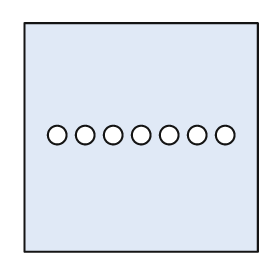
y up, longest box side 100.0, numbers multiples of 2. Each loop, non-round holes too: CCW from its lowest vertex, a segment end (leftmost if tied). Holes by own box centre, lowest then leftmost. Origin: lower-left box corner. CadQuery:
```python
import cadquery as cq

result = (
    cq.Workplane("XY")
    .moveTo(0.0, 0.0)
    .lineTo(100.0, 0.0)
    .lineTo(100.0, 98.0)
    .lineTo(0.0, 98.0)
    .close()
    .moveTo(14.0, 50.0)
    .circle(4.0)
    .moveTo(26.0, 50.0)
    .circle(4.0)
    .moveTo(38.0, 50.0)
    .circle(4.0)
    .moveTo(50.0, 50.0)
    .circle(4.0)
    .moveTo(62.0, 50.0)
    .circle(4.0)
    .moveTo(74.0, 50.0)
    .circle(4.0)
    .moveTo(86.0, 50.0)
    .circle(4.0)
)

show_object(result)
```